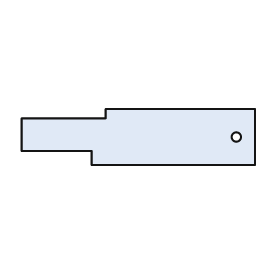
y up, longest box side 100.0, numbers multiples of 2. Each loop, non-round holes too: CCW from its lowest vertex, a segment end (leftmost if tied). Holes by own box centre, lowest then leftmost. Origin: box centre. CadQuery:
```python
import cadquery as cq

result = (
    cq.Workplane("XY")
    .moveTo(-20.0, -12.0)
    .lineTo(50.0, -12.0)
    .lineTo(50.0, 12.0)
    .lineTo(-14.0, 12.0)
    .lineTo(-14.0, 8.0)
    .lineTo(-50.0, 8.0)
    .lineTo(-50.0, -6.0)
    .lineTo(-20.0, -6.0)
    .close()
    .moveTo(42.0, 0.0)
    .circle(2.0)
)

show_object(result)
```